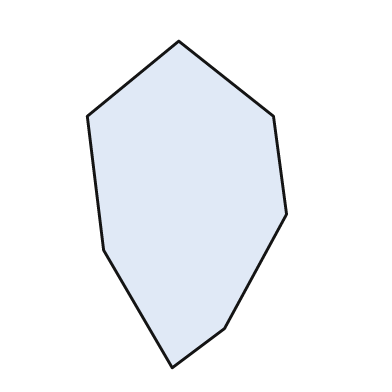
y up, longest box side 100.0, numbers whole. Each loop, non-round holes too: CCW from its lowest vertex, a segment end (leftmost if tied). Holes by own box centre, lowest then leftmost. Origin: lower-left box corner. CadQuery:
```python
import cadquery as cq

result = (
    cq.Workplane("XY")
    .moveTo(26.0, 0.0)
    .lineTo(42.0, 12.0)
    .lineTo(61.0, 47.0)
    .lineTo(57.0, 77.0)
    .lineTo(28.0, 100.0)
    .lineTo(0.0, 77.0)
    .lineTo(5.0, 36.0)
    .close()
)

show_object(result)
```